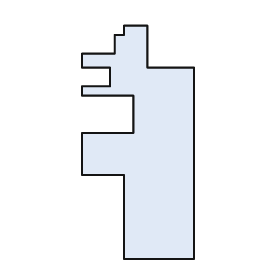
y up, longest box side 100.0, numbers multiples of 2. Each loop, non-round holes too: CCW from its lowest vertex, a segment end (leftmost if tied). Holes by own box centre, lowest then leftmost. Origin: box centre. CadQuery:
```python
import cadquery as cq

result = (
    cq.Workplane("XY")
    .moveTo(-6.0, -50.0)
    .lineTo(24.0, -50.0)
    .lineTo(24.0, 32.0)
    .lineTo(4.0, 32.0)
    .lineTo(4.0, 50.0)
    .lineTo(-6.0, 50.0)
    .lineTo(-6.0, 46.0)
    .lineTo(-10.0, 46.0)
    .lineTo(-10.0, 38.0)
    .lineTo(-24.0, 38.0)
    .lineTo(-24.0, 32.0)
    .lineTo(-12.0, 32.0)
    .lineTo(-12.0, 24.0)
    .lineTo(-24.0, 24.0)
    .lineTo(-24.0, 20.0)
    .lineTo(-2.0, 20.0)
    .lineTo(-2.0, 4.0)
    .lineTo(-24.0, 4.0)
    .lineTo(-24.0, -14.0)
    .lineTo(-6.0, -14.0)
    .close()
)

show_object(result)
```